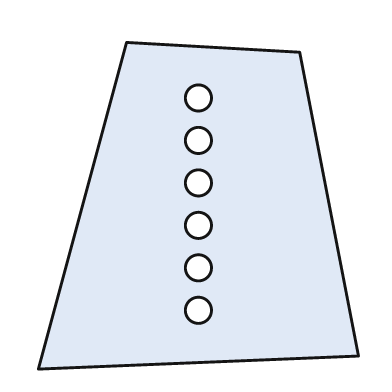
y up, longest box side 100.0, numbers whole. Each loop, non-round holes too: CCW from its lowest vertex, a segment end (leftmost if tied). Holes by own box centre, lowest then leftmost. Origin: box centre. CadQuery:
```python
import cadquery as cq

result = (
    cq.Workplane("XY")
    .moveTo(-49.0, -50.0)
    .lineTo(49.0, -46.0)
    .lineTo(31.0, 47.0)
    .lineTo(-22.0, 50.0)
    .close()
    .moveTo(0.0, -32.0)
    .circle(4.0)
    .moveTo(0.0, -19.0)
    .circle(4.0)
    .moveTo(0.0, -6.0)
    .circle(4.0)
    .moveTo(0.0, 7.0)
    .circle(4.0)
    .moveTo(0.0, 20.0)
    .circle(4.0)
    .moveTo(0.0, 33.0)
    .circle(4.0)
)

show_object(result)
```